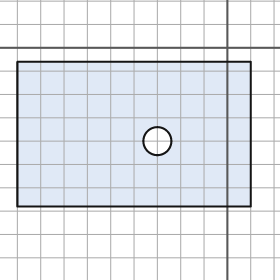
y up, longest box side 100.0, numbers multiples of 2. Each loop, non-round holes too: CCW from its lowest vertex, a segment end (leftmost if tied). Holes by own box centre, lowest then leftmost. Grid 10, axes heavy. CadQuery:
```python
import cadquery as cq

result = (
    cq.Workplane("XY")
    .moveTo(-90.0, -68.0)
    .lineTo(10.0, -68.0)
    .lineTo(10.0, -6.0)
    .lineTo(-90.0, -6.0)
    .close()
    .moveTo(-30.0, -40.0)
    .circle(6.0)
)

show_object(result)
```